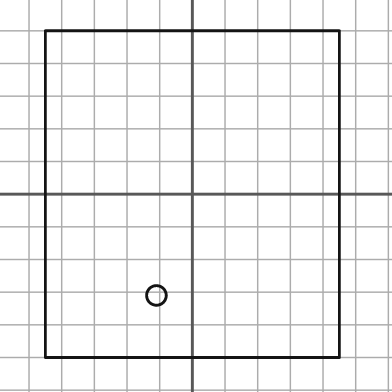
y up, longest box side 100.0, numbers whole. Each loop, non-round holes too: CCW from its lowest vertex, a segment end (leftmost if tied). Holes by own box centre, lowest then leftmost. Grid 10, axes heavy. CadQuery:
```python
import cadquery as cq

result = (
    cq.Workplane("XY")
    .moveTo(-45.0, -50.0)
    .lineTo(45.0, -50.0)
    .lineTo(45.0, 50.0)
    .lineTo(-45.0, 50.0)
    .close()
    .moveTo(-11.0, -31.0)
    .circle(3.0)
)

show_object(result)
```